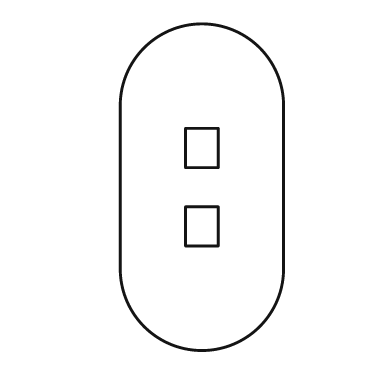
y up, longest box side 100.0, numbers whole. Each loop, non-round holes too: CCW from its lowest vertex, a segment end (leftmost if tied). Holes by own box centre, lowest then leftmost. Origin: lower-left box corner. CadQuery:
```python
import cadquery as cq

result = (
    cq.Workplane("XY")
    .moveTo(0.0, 25.0)
    .threePointArc((25.0, 0.0), (50.0, 25.0))
    .lineTo(50.0, 75.0)
    .threePointArc((25.0, 100.0), (0.0, 75.0))
    .close()
    .moveTo(20.0, 32.0)
    .lineTo(30.0, 32.0)
    .lineTo(30.0, 44.0)
    .lineTo(20.0, 44.0)
    .close()
    .moveTo(20.0, 56.0)
    .lineTo(30.0, 56.0)
    .lineTo(30.0, 68.0)
    .lineTo(20.0, 68.0)
    .close()
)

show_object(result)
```